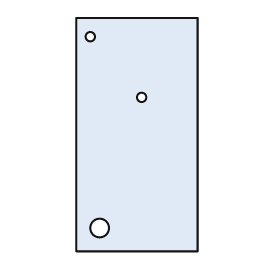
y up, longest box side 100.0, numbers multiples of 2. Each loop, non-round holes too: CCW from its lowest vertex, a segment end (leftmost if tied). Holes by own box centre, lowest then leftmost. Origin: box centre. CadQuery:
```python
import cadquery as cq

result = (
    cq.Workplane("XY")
    .moveTo(-26.0, -50.0)
    .lineTo(26.0, -50.0)
    .lineTo(26.0, 50.0)
    .lineTo(-26.0, 50.0)
    .close()
    .moveTo(-16.0, -40.0)
    .circle(4.0)
    .moveTo(2.0, 16.0)
    .circle(2.0)
    .moveTo(-20.0, 42.0)
    .circle(2.0)
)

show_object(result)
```